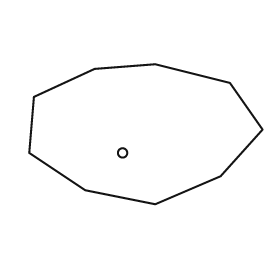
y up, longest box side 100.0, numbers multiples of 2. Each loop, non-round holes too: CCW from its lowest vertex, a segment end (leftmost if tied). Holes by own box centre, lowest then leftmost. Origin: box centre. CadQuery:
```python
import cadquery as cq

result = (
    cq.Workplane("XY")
    .moveTo(4.0, -30.0)
    .lineTo(32.0, -18.0)
    .lineTo(50.0, 2.0)
    .lineTo(36.0, 22.0)
    .lineTo(4.0, 30.0)
    .lineTo(-22.0, 28.0)
    .lineTo(-48.0, 16.0)
    .lineTo(-50.0, -8.0)
    .lineTo(-26.0, -24.0)
    .close()
    .moveTo(-10.0, -8.0)
    .circle(2.0)
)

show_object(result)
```